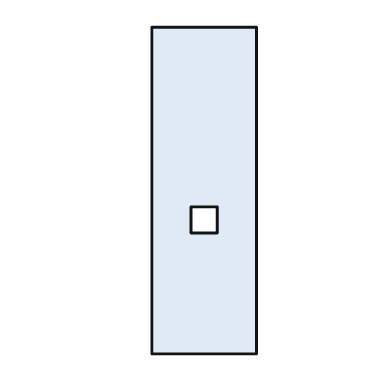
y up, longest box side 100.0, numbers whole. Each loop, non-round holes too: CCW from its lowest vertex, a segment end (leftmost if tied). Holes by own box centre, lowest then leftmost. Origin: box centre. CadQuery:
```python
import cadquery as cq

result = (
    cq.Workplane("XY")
    .moveTo(-16.0, -50.0)
    .lineTo(16.0, -50.0)
    .lineTo(16.0, 50.0)
    .lineTo(-16.0, 50.0)
    .close()
    .moveTo(-4.0, -13.0)
    .lineTo(4.0, -13.0)
    .lineTo(4.0, -5.0)
    .lineTo(-4.0, -5.0)
    .close()
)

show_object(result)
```